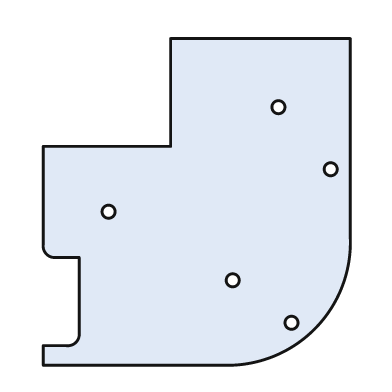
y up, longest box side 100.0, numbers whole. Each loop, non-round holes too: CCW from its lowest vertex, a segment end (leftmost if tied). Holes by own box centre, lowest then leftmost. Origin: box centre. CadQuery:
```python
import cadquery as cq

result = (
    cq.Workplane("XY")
    .moveTo(-47.0, -50.0)
    .lineTo(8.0, -50.0)
    .threePointArc((36.0, -39.0), (47.0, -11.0))
    .lineTo(47.0, 50.0)
    .lineTo(-8.0, 50.0)
    .lineTo(-8.0, 17.0)
    .lineTo(-47.0, 17.0)
    .lineTo(-47.0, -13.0)
    .threePointArc((-46.0, -16.0), (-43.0, -17.0))
    .lineTo(-36.0, -17.0)
    .lineTo(-36.0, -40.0)
    .threePointArc((-37.0, -43.0), (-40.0, -44.0))
    .lineTo(-47.0, -44.0)
    .close()
    .moveTo(29.0, -37.0)
    .circle(2.0)
    .moveTo(11.0, -24.0)
    .circle(2.0)
    .moveTo(-27.0, -3.0)
    .circle(2.0)
    .moveTo(41.0, 10.0)
    .circle(2.0)
    .moveTo(25.0, 29.0)
    .circle(2.0)
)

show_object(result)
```